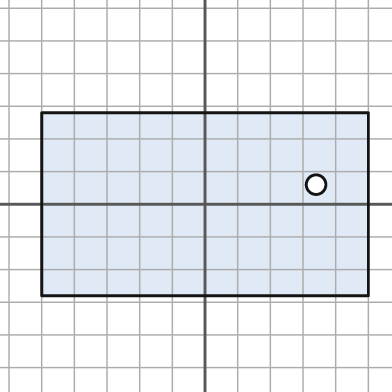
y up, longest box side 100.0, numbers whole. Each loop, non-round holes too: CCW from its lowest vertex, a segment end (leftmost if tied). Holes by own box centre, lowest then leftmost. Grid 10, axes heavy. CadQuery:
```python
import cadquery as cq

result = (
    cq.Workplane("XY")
    .moveTo(-50.0, -28.0)
    .lineTo(50.0, -28.0)
    .lineTo(50.0, 28.0)
    .lineTo(-50.0, 28.0)
    .close()
    .moveTo(34.0, 6.0)
    .circle(3.0)
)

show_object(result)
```